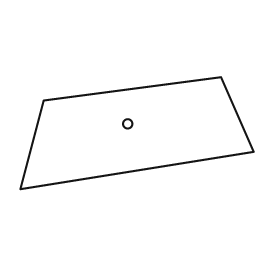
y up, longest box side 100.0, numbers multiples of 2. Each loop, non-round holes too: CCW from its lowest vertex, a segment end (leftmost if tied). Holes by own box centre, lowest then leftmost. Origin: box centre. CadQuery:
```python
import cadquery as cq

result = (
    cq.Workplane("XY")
    .moveTo(-50.0, -24.0)
    .lineTo(50.0, -8.0)
    .lineTo(36.0, 24.0)
    .lineTo(-40.0, 14.0)
    .close()
    .moveTo(-4.0, 4.0)
    .circle(2.0)
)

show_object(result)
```